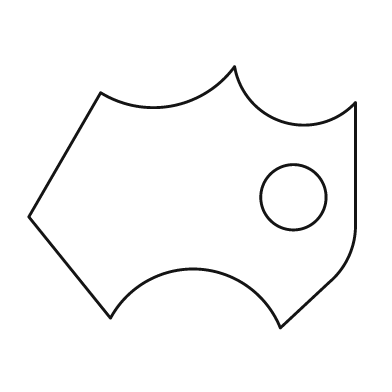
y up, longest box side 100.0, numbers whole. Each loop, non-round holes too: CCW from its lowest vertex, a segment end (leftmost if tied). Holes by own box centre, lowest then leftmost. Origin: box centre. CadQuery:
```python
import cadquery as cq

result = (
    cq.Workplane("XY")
    .moveTo(27.0, -40.0)
    .lineTo(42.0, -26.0)
    .threePointArc((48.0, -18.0), (50.0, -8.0))
    .lineTo(50.0, 29.0)
    .threePointArc((28.0, 23.0), (13.0, 40.0))
    .threePointArc((-6.0, 28.0), (-28.0, 32.0))
    .lineTo(-50.0, -6.0)
    .lineTo(-25.0, -37.0)
    .threePointArc((2.0, -22.0), (27.0, -40.0))
    .close()
    .moveTo(31.0, 0.0)
    .circle(10.0)
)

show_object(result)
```